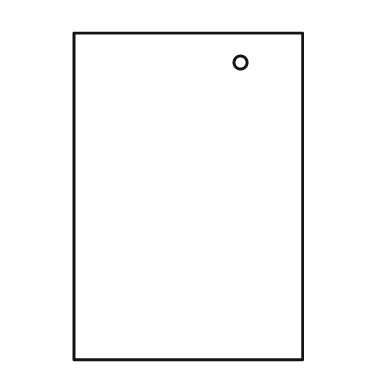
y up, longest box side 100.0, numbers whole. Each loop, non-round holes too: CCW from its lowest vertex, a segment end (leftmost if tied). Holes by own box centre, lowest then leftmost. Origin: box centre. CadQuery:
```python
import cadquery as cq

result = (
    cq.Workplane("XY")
    .moveTo(-35.0, -50.0)
    .lineTo(35.0, -50.0)
    .lineTo(35.0, 50.0)
    .lineTo(-35.0, 50.0)
    .close()
    .moveTo(16.0, 41.0)
    .circle(2.0)
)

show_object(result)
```